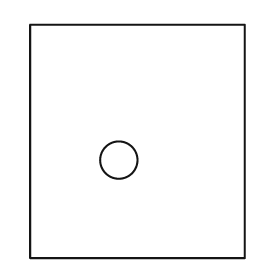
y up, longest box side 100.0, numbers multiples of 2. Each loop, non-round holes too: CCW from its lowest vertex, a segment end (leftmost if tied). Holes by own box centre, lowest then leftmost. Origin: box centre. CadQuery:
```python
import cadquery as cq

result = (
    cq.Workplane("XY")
    .moveTo(-46.0, -50.0)
    .lineTo(46.0, -50.0)
    .lineTo(46.0, 50.0)
    .lineTo(-46.0, 50.0)
    .close()
    .moveTo(-8.0, -8.0)
    .circle(8.0)
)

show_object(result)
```